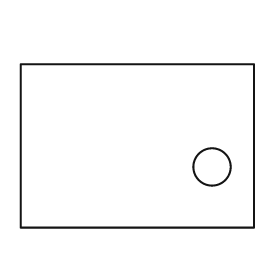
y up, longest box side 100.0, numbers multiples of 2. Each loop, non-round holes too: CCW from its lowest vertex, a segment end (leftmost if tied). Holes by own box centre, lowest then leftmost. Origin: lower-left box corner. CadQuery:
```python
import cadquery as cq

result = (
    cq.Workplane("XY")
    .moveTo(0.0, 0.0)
    .lineTo(100.0, 0.0)
    .lineTo(100.0, 70.0)
    .lineTo(0.0, 70.0)
    .close()
    .moveTo(82.0, 26.0)
    .circle(8.0)
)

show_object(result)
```